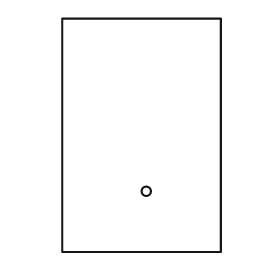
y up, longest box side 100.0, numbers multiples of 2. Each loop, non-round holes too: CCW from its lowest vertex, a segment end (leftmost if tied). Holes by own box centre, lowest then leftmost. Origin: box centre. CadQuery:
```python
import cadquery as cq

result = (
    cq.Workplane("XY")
    .moveTo(-34.0, -50.0)
    .lineTo(34.0, -50.0)
    .lineTo(34.0, 50.0)
    .lineTo(-34.0, 50.0)
    .close()
    .moveTo(2.0, -24.0)
    .circle(2.0)
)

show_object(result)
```